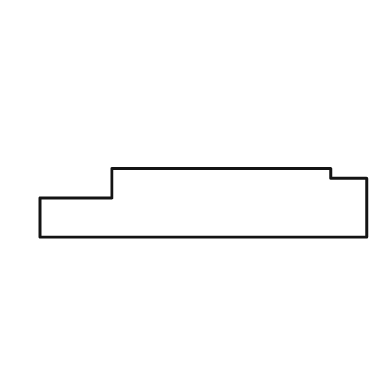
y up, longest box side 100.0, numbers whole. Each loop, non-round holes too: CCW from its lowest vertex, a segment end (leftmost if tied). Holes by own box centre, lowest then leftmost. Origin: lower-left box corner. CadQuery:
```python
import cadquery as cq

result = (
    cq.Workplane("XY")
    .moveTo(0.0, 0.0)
    .lineTo(100.0, 0.0)
    .lineTo(100.0, 18.0)
    .lineTo(89.0, 18.0)
    .lineTo(89.0, 21.0)
    .lineTo(22.0, 21.0)
    .lineTo(22.0, 12.0)
    .lineTo(0.0, 12.0)
    .close()
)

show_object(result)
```